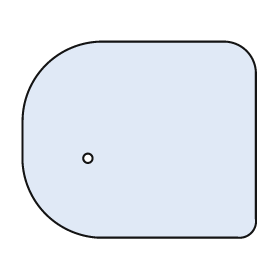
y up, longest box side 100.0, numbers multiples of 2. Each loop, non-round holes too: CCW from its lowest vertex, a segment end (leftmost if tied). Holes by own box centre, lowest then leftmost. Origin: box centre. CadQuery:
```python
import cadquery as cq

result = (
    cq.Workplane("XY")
    .moveTo(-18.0, -42.0)
    .lineTo(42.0, -42.0)
    .threePointArc((48.0, -40.0), (50.0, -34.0))
    .lineTo(50.0, 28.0)
    .threePointArc((46.0, 38.0), (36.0, 42.0))
    .lineTo(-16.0, 42.0)
    .threePointArc((-40.0, 32.0), (-50.0, 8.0))
    .lineTo(-50.0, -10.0)
    .threePointArc((-40.0, -32.0), (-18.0, -42.0))
    .close()
    .moveTo(-22.0, -8.0)
    .circle(2.0)
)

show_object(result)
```